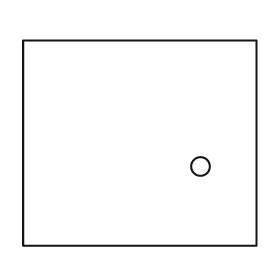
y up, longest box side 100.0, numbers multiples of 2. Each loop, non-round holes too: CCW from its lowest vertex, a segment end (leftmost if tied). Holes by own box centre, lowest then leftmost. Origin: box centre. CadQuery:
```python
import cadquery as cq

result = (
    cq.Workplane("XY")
    .moveTo(-50.0, -44.0)
    .lineTo(50.0, -44.0)
    .lineTo(50.0, 44.0)
    .lineTo(-50.0, 44.0)
    .close()
    .moveTo(26.0, -10.0)
    .circle(4.0)
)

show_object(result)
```